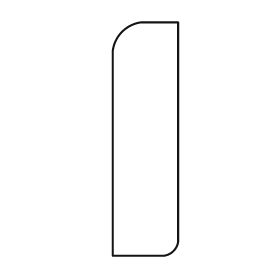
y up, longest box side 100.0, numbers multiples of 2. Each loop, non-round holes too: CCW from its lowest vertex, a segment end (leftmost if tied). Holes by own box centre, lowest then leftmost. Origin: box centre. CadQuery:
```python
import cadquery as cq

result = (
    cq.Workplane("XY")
    .moveTo(-14.0, -50.0)
    .lineTo(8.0, -50.0)
    .threePointArc((12.0, -48.0), (14.0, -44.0))
    .lineTo(14.0, 50.0)
    .lineTo(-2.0, 50.0)
    .threePointArc((-10.0, 46.0), (-14.0, 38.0))
    .close()
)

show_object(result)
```